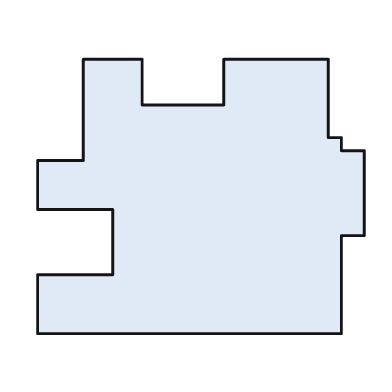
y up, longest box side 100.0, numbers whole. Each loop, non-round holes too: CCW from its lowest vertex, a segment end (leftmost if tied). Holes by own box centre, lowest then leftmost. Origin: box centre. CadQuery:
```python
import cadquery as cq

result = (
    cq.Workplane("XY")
    .moveTo(-50.0, -42.0)
    .lineTo(43.0, -42.0)
    .lineTo(43.0, -12.0)
    .lineTo(50.0, -12.0)
    .lineTo(50.0, 14.0)
    .lineTo(43.0, 14.0)
    .lineTo(43.0, 18.0)
    .lineTo(39.0, 18.0)
    .lineTo(39.0, 42.0)
    .lineTo(7.0, 42.0)
    .lineTo(7.0, 28.0)
    .lineTo(-18.0, 28.0)
    .lineTo(-18.0, 42.0)
    .lineTo(-36.0, 42.0)
    .lineTo(-36.0, 11.0)
    .lineTo(-50.0, 11.0)
    .lineTo(-50.0, -4.0)
    .lineTo(-27.0, -4.0)
    .lineTo(-27.0, -24.0)
    .lineTo(-50.0, -24.0)
    .close()
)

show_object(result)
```